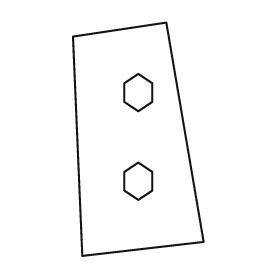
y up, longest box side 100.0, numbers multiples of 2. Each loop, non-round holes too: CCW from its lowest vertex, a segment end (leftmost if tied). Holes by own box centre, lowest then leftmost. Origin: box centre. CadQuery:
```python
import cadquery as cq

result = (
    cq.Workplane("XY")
    .moveTo(-24.0, -50.0)
    .lineTo(28.0, -44.0)
    .lineTo(12.0, 50.0)
    .lineTo(-28.0, 44.0)
    .close()
    .moveTo(0.0, -26.0)
    .lineTo(6.0, -22.0)
    .lineTo(6.0, -14.0)
    .lineTo(0.0, -10.0)
    .lineTo(-6.0, -14.0)
    .lineTo(-6.0, -22.0)
    .close()
    .moveTo(0.0, 12.0)
    .lineTo(6.0, 16.0)
    .lineTo(6.0, 24.0)
    .lineTo(0.0, 28.0)
    .lineTo(-6.0, 24.0)
    .lineTo(-6.0, 16.0)
    .close()
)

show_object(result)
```